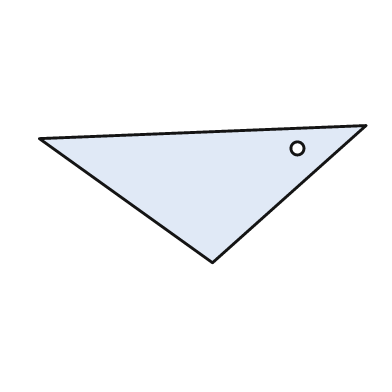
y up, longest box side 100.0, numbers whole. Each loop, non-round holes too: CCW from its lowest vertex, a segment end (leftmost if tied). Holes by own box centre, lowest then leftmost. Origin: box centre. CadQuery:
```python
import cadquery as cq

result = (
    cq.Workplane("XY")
    .moveTo(3.0, -21.0)
    .lineTo(50.0, 21.0)
    .lineTo(-50.0, 17.0)
    .close()
    .moveTo(29.0, 14.0)
    .circle(2.0)
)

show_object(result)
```